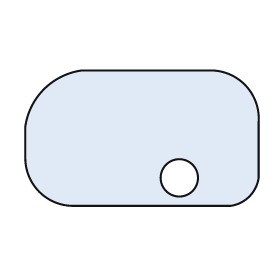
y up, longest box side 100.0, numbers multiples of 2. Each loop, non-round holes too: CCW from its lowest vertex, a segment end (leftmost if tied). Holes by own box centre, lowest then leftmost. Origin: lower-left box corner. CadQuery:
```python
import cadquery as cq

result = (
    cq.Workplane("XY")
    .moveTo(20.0, 0.0)
    .lineTo(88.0, 0.0)
    .threePointArc((96.0, 4.0), (100.0, 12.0))
    .lineTo(100.0, 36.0)
    .threePointArc((94.0, 52.0), (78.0, 58.0))
    .lineTo(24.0, 58.0)
    .threePointArc((8.0, 50.0), (0.0, 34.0))
    .lineTo(0.0, 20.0)
    .threePointArc((6.0, 6.0), (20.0, 0.0))
    .close()
    .moveTo(66.0, 12.0)
    .circle(8.0)
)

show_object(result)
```